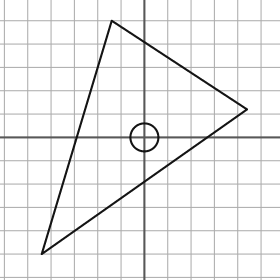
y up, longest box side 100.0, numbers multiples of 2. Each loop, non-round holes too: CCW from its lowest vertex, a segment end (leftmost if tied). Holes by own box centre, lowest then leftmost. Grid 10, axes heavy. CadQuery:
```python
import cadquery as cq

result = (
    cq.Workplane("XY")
    .moveTo(-44.0, -50.0)
    .lineTo(44.0, 12.0)
    .lineTo(-14.0, 50.0)
    .close()
    .moveTo(0.0, 0.0)
    .circle(6.0)
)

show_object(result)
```